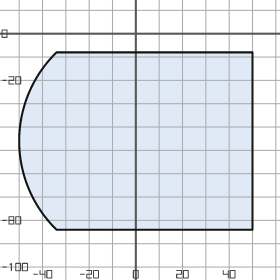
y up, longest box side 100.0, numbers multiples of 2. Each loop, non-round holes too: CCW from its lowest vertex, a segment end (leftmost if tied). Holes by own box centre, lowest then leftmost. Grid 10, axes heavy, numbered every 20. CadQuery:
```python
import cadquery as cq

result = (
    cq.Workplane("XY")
    .moveTo(-34.0, -84.0)
    .lineTo(50.0, -84.0)
    .lineTo(50.0, -8.0)
    .lineTo(-34.0, -8.0)
    .threePointArc((-50.0, -46.0), (-34.0, -84.0))
    .close()
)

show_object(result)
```